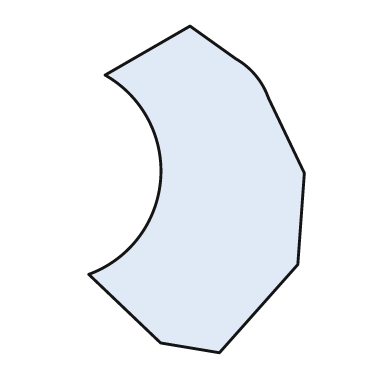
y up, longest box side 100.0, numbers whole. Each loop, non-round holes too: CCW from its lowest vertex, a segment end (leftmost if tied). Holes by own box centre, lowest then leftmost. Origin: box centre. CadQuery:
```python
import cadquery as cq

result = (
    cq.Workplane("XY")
    .moveTo(7.0, -50.0)
    .lineTo(31.0, -23.0)
    .lineTo(33.0, 5.0)
    .lineTo(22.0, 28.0)
    .threePointArc((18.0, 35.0), (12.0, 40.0))
    .lineTo(-2.0, 50.0)
    .lineTo(-28.0, 35.0)
    .threePointArc((-11.0, 3.0), (-33.0, -26.0))
    .lineTo(-11.0, -47.0)
    .close()
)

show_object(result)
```